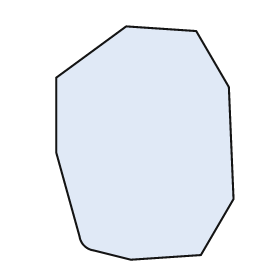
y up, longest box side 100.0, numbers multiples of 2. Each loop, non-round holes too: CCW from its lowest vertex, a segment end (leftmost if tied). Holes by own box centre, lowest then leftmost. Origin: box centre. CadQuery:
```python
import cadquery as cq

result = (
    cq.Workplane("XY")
    .moveTo(-6.0, -50.0)
    .lineTo(24.0, -48.0)
    .lineTo(38.0, -24.0)
    .lineTo(36.0, 24.0)
    .lineTo(22.0, 48.0)
    .lineTo(-8.0, 50.0)
    .lineTo(-38.0, 28.0)
    .lineTo(-38.0, -4.0)
    .lineTo(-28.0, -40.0)
    .threePointArc((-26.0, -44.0), (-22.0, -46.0))
    .close()
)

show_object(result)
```